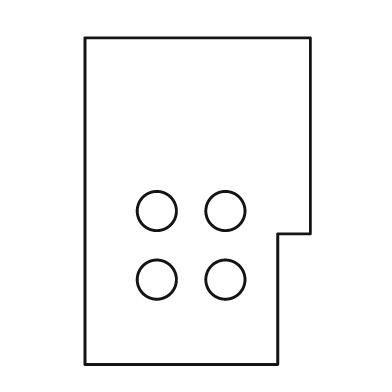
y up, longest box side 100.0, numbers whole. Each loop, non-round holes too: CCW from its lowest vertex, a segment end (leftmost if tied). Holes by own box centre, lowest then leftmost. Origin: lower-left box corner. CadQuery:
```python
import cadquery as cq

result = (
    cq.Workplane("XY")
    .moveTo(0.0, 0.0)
    .lineTo(59.0, 0.0)
    .lineTo(59.0, 40.0)
    .lineTo(69.0, 40.0)
    .lineTo(69.0, 100.0)
    .lineTo(0.0, 100.0)
    .close()
    .moveTo(22.0, 26.0)
    .circle(6.0)
    .moveTo(43.0, 26.0)
    .circle(6.0)
    .moveTo(22.0, 47.0)
    .circle(6.0)
    .moveTo(43.0, 47.0)
    .circle(6.0)
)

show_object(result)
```